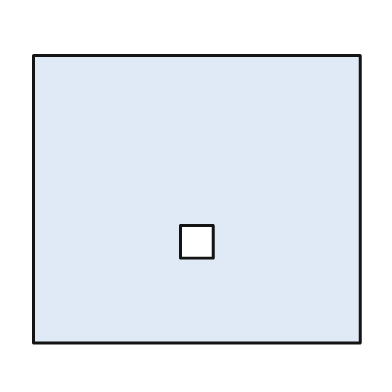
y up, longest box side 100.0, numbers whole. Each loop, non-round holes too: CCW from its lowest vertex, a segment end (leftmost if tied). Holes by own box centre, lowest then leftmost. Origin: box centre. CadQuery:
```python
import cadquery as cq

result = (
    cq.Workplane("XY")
    .moveTo(-50.0, -44.0)
    .lineTo(50.0, -44.0)
    .lineTo(50.0, 44.0)
    .lineTo(-50.0, 44.0)
    .close()
    .moveTo(-5.0, -18.0)
    .lineTo(5.0, -18.0)
    .lineTo(5.0, -8.0)
    .lineTo(-5.0, -8.0)
    .close()
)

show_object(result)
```